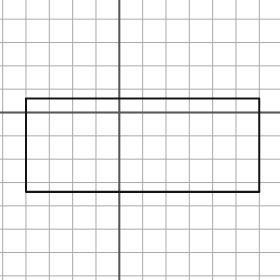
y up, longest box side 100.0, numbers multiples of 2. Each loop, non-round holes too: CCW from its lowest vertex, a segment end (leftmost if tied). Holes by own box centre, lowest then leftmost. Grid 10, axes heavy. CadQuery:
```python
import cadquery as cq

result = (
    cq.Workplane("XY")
    .moveTo(-40.0, -34.0)
    .lineTo(60.0, -34.0)
    .lineTo(60.0, 6.0)
    .lineTo(-40.0, 6.0)
    .close()
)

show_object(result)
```